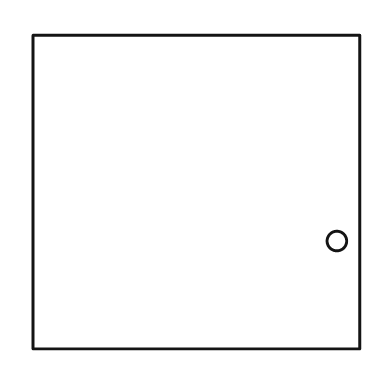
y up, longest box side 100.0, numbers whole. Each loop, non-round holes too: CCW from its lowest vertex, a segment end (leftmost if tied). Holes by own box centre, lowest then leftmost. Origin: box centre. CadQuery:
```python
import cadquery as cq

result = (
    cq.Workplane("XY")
    .moveTo(-50.0, -48.0)
    .lineTo(50.0, -48.0)
    .lineTo(50.0, 48.0)
    .lineTo(-50.0, 48.0)
    .close()
    .moveTo(43.0, -15.0)
    .circle(3.0)
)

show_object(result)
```